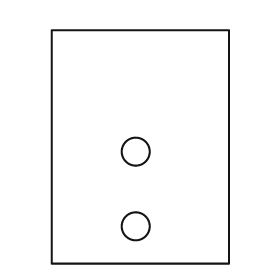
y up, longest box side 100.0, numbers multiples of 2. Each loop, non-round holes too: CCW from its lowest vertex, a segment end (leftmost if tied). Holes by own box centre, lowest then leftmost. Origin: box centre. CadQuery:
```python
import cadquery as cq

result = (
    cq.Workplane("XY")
    .moveTo(-38.0, -50.0)
    .lineTo(38.0, -50.0)
    .lineTo(38.0, 50.0)
    .lineTo(-38.0, 50.0)
    .close()
    .moveTo(-2.0, -34.0)
    .circle(6.0)
    .moveTo(-2.0, -2.0)
    .circle(6.0)
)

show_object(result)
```